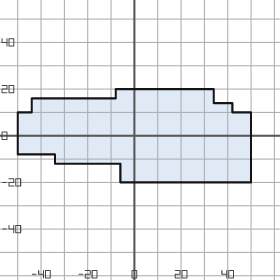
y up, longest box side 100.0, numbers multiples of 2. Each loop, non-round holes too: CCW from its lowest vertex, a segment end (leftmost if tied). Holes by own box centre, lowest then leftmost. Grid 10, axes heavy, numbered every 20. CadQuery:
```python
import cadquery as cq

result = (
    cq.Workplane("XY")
    .moveTo(-6.0, -20.0)
    .lineTo(50.0, -20.0)
    .lineTo(50.0, 10.0)
    .lineTo(42.0, 10.0)
    .lineTo(42.0, 14.0)
    .lineTo(34.0, 14.0)
    .lineTo(34.0, 20.0)
    .lineTo(-8.0, 20.0)
    .lineTo(-8.0, 16.0)
    .lineTo(-44.0, 16.0)
    .lineTo(-44.0, 10.0)
    .lineTo(-50.0, 10.0)
    .lineTo(-50.0, -8.0)
    .lineTo(-34.0, -8.0)
    .lineTo(-34.0, -12.0)
    .lineTo(-6.0, -12.0)
    .close()
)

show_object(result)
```